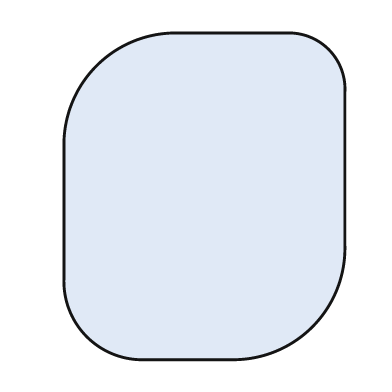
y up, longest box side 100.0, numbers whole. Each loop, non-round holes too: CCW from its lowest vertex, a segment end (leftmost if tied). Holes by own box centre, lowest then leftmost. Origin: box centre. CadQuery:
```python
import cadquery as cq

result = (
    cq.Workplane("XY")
    .moveTo(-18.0, -50.0)
    .lineTo(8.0, -50.0)
    .threePointArc((33.0, -40.0), (43.0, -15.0))
    .lineTo(43.0, 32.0)
    .threePointArc((38.0, 45.0), (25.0, 50.0))
    .lineTo(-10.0, 50.0)
    .threePointArc((-33.0, 40.0), (-43.0, 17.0))
    .lineTo(-43.0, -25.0)
    .threePointArc((-36.0, -43.0), (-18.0, -50.0))
    .close()
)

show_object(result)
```